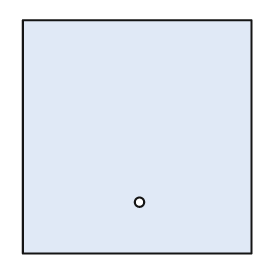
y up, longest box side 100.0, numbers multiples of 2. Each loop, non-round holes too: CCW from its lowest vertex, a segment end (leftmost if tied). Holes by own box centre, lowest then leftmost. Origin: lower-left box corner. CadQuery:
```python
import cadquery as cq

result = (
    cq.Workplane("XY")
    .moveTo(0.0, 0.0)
    .lineTo(98.0, 0.0)
    .lineTo(98.0, 100.0)
    .lineTo(0.0, 100.0)
    .close()
    .moveTo(50.0, 22.0)
    .circle(2.0)
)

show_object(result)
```